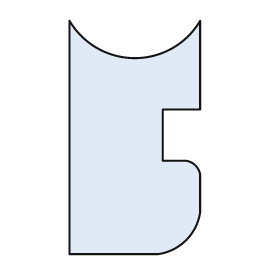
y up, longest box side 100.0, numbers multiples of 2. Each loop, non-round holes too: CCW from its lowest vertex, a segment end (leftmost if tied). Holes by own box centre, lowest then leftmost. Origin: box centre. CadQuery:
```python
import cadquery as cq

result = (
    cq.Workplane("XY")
    .moveTo(-28.0, -50.0)
    .lineTo(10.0, -50.0)
    .threePointArc((22.0, -44.0), (28.0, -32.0))
    .lineTo(28.0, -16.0)
    .threePointArc((26.0, -12.0), (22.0, -10.0))
    .lineTo(12.0, -10.0)
    .lineTo(12.0, 12.0)
    .lineTo(28.0, 12.0)
    .lineTo(28.0, 50.0)
    .threePointArc((0.0, 34.0), (-28.0, 50.0))
    .close()
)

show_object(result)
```